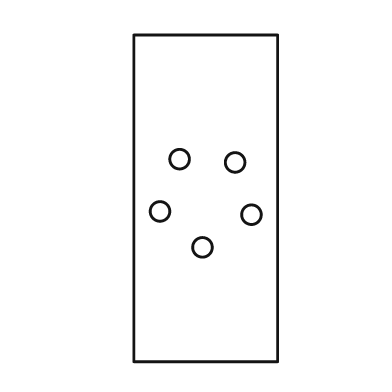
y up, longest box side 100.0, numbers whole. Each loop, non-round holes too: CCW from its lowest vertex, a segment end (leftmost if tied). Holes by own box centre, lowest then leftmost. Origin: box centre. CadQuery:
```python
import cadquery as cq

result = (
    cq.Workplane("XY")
    .moveTo(-22.0, -50.0)
    .lineTo(22.0, -50.0)
    .lineTo(22.0, 50.0)
    .lineTo(-22.0, 50.0)
    .close()
    .moveTo(-1.0, -15.0)
    .circle(3.0)
    .moveTo(14.0, -5.0)
    .circle(3.0)
    .moveTo(-14.0, -4.0)
    .circle(3.0)
    .moveTo(9.0, 11.0)
    .circle(3.0)
    .moveTo(-8.0, 12.0)
    .circle(3.0)
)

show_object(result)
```